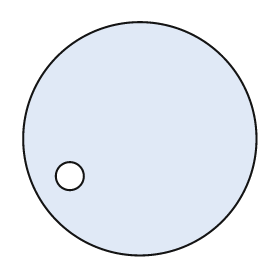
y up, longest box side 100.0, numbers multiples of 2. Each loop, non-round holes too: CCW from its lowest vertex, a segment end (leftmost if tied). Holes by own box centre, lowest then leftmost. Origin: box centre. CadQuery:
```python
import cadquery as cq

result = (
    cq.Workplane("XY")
    .moveTo(0.0, 0.0)
    .circle(50.0)
    .moveTo(-30.0, -16.0)
    .circle(6.0)
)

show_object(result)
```